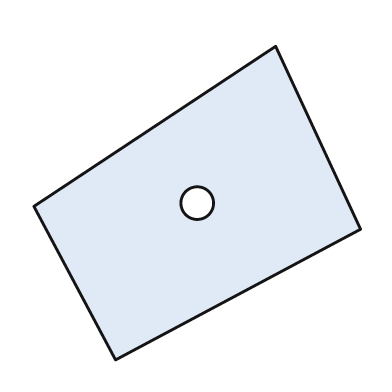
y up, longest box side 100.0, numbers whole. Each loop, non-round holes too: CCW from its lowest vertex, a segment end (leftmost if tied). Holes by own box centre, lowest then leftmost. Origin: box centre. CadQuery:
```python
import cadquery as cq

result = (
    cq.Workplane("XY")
    .moveTo(-25.0, -48.0)
    .lineTo(50.0, -8.0)
    .lineTo(24.0, 48.0)
    .lineTo(-50.0, -1.0)
    .close()
    .moveTo(0.0, 0.0)
    .circle(5.0)
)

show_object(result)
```